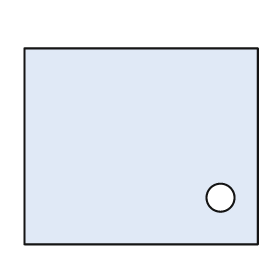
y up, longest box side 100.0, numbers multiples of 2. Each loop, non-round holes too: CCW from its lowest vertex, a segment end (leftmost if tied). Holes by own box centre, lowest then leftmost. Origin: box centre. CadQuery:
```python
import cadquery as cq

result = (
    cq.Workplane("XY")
    .moveTo(-50.0, -42.0)
    .lineTo(50.0, -42.0)
    .lineTo(50.0, 42.0)
    .lineTo(-50.0, 42.0)
    .close()
    .moveTo(34.0, -22.0)
    .circle(6.0)
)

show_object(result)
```